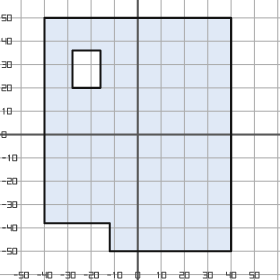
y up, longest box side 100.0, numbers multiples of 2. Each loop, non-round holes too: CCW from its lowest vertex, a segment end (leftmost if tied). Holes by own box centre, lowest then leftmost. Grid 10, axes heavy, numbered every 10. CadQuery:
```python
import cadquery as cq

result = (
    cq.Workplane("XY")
    .moveTo(-12.0, -50.0)
    .lineTo(40.0, -50.0)
    .lineTo(40.0, 50.0)
    .lineTo(-40.0, 50.0)
    .lineTo(-40.0, -38.0)
    .lineTo(-12.0, -38.0)
    .close()
    .moveTo(-28.0, 20.0)
    .lineTo(-16.0, 20.0)
    .lineTo(-16.0, 36.0)
    .lineTo(-28.0, 36.0)
    .close()
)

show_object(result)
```